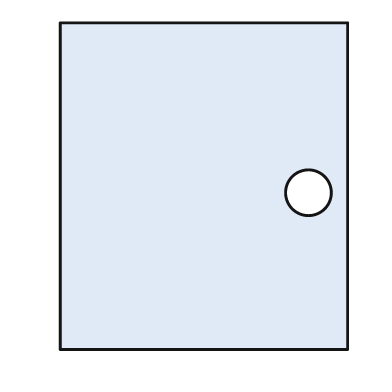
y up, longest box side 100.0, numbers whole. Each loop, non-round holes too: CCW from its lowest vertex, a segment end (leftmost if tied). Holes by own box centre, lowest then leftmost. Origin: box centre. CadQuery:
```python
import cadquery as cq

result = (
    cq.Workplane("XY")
    .moveTo(-44.0, -50.0)
    .lineTo(44.0, -50.0)
    .lineTo(44.0, 50.0)
    .lineTo(-44.0, 50.0)
    .close()
    .moveTo(32.0, -2.0)
    .circle(7.0)
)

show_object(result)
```